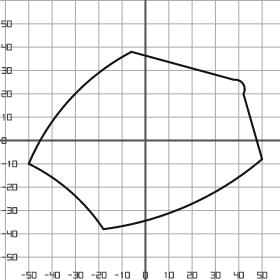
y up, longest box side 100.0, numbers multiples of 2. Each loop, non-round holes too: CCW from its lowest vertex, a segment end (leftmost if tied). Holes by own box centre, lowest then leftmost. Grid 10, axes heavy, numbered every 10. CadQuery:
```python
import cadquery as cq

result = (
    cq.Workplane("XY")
    .moveTo(-18.0, -38.0)
    .threePointArc((18.0, -28.0), (50.0, -8.0))
    .lineTo(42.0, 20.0)
    .threePointArc((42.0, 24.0), (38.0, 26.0))
    .lineTo(-6.0, 38.0)
    .threePointArc((-32.0, 18.0), (-50.0, -10.0))
    .threePointArc((-32.0, -22.0), (-18.0, -38.0))
    .close()
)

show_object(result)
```